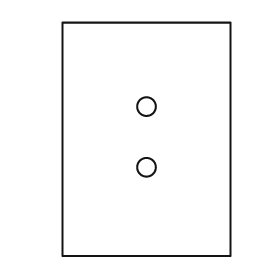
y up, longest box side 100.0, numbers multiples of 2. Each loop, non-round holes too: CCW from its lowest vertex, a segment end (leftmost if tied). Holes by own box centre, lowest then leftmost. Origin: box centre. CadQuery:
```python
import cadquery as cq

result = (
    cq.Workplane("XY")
    .moveTo(-36.0, -50.0)
    .lineTo(36.0, -50.0)
    .lineTo(36.0, 50.0)
    .lineTo(-36.0, 50.0)
    .close()
    .moveTo(0.0, -12.0)
    .circle(4.0)
    .moveTo(0.0, 14.0)
    .circle(4.0)
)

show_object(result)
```